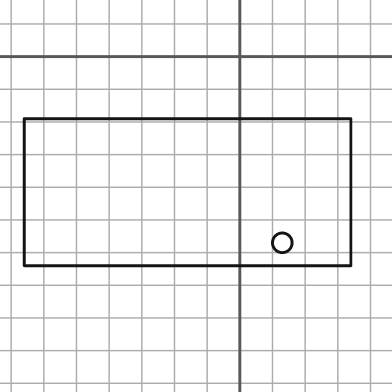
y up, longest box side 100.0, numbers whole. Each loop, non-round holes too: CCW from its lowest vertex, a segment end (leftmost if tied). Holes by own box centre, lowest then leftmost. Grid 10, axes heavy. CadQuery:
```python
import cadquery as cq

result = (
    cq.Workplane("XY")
    .moveTo(-66.0, -64.0)
    .lineTo(34.0, -64.0)
    .lineTo(34.0, -19.0)
    .lineTo(-66.0, -19.0)
    .close()
    .moveTo(13.0, -57.0)
    .circle(3.0)
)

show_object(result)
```